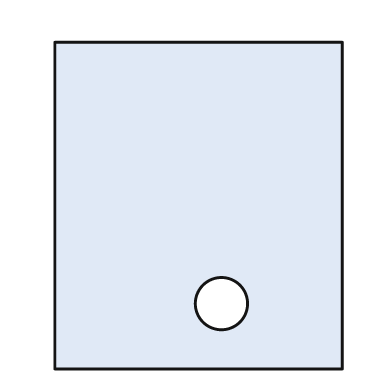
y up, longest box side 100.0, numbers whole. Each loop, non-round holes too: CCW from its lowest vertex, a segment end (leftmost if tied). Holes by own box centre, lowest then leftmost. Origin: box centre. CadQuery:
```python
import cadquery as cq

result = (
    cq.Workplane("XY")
    .moveTo(-44.0, -50.0)
    .lineTo(44.0, -50.0)
    .lineTo(44.0, 50.0)
    .lineTo(-44.0, 50.0)
    .close()
    .moveTo(7.0, -30.0)
    .circle(8.0)
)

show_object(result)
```